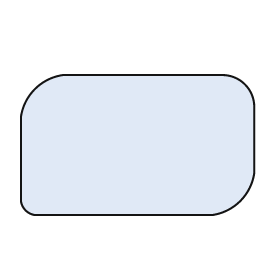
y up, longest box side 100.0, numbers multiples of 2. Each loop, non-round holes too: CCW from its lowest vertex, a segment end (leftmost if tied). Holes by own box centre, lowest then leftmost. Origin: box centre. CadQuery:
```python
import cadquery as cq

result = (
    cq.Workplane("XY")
    .moveTo(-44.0, -30.0)
    .lineTo(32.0, -30.0)
    .threePointArc((44.0, -24.0), (50.0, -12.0))
    .lineTo(50.0, 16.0)
    .threePointArc((46.0, 26.0), (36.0, 30.0))
    .lineTo(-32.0, 30.0)
    .threePointArc((-44.0, 24.0), (-50.0, 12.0))
    .lineTo(-50.0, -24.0)
    .threePointArc((-48.0, -28.0), (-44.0, -30.0))
    .close()
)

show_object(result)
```